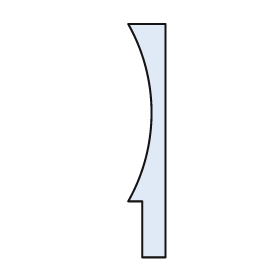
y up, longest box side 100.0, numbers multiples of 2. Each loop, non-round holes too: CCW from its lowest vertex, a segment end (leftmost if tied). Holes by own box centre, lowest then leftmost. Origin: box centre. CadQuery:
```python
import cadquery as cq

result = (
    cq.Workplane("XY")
    .moveTo(-2.0, -50.0)
    .lineTo(8.0, -50.0)
    .lineTo(8.0, 50.0)
    .lineTo(-8.0, 50.0)
    .threePointArc((2.0, 12.0), (-8.0, -26.0))
    .lineTo(-2.0, -26.0)
    .close()
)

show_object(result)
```